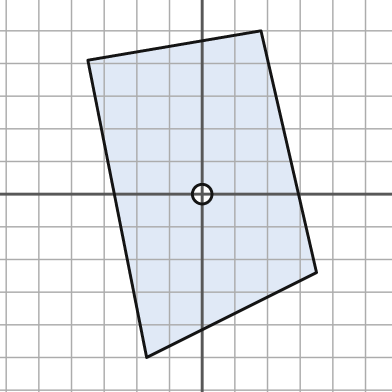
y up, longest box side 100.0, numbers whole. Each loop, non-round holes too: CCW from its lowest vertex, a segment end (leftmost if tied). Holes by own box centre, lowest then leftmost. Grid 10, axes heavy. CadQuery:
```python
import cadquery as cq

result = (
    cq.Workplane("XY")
    .moveTo(-17.0, -50.0)
    .lineTo(35.0, -24.0)
    .lineTo(18.0, 50.0)
    .lineTo(-35.0, 41.0)
    .close()
    .moveTo(0.0, 0.0)
    .circle(3.0)
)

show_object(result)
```